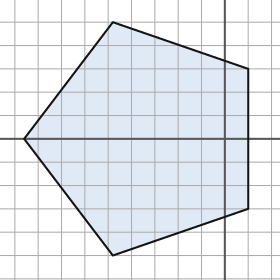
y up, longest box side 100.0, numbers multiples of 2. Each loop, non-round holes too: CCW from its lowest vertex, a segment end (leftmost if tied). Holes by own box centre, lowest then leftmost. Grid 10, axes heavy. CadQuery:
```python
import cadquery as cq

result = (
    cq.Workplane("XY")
    .moveTo(-48.0, -50.0)
    .lineTo(10.0, -30.0)
    .lineTo(10.0, 30.0)
    .lineTo(-48.0, 50.0)
    .lineTo(-86.0, 0.0)
    .close()
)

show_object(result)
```